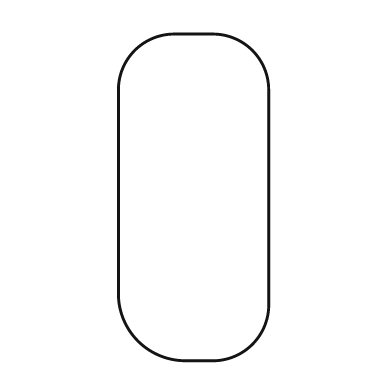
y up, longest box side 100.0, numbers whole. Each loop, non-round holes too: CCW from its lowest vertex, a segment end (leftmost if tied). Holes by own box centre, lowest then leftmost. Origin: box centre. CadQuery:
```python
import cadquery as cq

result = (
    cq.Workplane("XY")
    .moveTo(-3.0, -50.0)
    .lineTo(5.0, -50.0)
    .threePointArc((18.0, -45.0), (23.0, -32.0))
    .lineTo(23.0, 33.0)
    .threePointArc((18.0, 45.0), (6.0, 50.0))
    .lineTo(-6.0, 50.0)
    .threePointArc((-18.0, 45.0), (-23.0, 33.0))
    .lineTo(-23.0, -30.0)
    .threePointArc((-17.0, -44.0), (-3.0, -50.0))
    .close()
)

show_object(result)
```